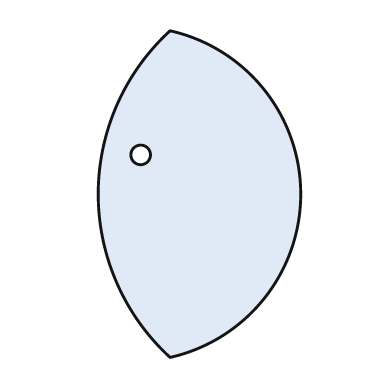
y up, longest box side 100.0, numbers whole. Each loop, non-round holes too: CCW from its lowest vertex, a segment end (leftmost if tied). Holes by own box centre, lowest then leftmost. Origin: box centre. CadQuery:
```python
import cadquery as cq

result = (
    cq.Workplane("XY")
    .moveTo(-9.0, -50.0)
    .threePointArc((31.0, 0.0), (-9.0, 50.0))
    .threePointArc((-31.0, 0.0), (-9.0, -50.0))
    .close()
    .moveTo(-18.0, 12.0)
    .circle(3.0)
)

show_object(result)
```